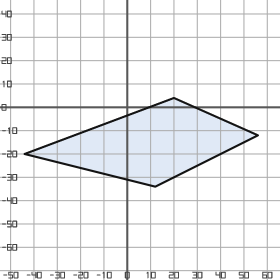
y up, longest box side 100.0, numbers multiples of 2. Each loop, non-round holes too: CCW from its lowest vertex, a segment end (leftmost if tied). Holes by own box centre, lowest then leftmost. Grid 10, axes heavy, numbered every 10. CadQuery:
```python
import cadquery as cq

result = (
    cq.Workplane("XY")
    .moveTo(12.0, -34.0)
    .lineTo(56.0, -12.0)
    .lineTo(20.0, 4.0)
    .lineTo(-44.0, -20.0)
    .close()
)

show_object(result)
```